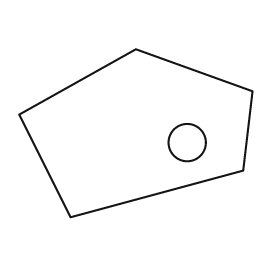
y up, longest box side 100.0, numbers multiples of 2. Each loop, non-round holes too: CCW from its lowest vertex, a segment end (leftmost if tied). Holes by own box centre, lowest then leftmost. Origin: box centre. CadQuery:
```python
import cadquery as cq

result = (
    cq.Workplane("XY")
    .moveTo(-28.0, -36.0)
    .lineTo(46.0, -16.0)
    .lineTo(50.0, 18.0)
    .lineTo(0.0, 36.0)
    .lineTo(-50.0, 8.0)
    .close()
    .moveTo(22.0, -4.0)
    .circle(8.0)
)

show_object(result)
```